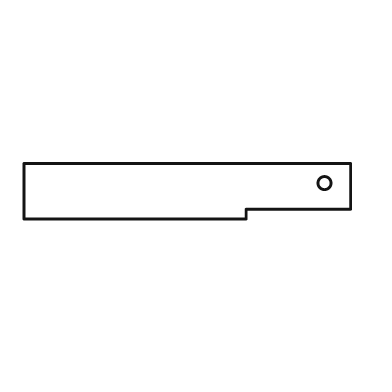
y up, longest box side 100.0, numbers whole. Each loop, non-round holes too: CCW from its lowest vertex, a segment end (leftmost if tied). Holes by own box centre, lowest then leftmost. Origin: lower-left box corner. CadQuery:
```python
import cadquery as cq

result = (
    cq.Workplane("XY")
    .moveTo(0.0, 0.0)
    .lineTo(68.0, 0.0)
    .lineTo(68.0, 3.0)
    .lineTo(100.0, 3.0)
    .lineTo(100.0, 17.0)
    .lineTo(0.0, 17.0)
    .close()
    .moveTo(92.0, 11.0)
    .circle(2.0)
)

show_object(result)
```